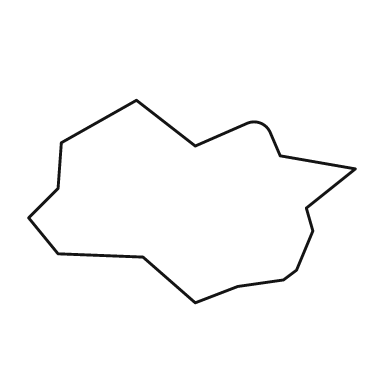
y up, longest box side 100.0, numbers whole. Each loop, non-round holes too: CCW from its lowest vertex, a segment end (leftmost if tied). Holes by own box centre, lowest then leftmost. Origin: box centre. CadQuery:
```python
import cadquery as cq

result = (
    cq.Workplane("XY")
    .moveTo(1.0, -31.0)
    .lineTo(14.0, -26.0)
    .lineTo(28.0, -24.0)
    .lineTo(32.0, -21.0)
    .lineTo(37.0, -9.0)
    .lineTo(35.0, -2.0)
    .lineTo(50.0, 10.0)
    .lineTo(27.0, 14.0)
    .lineTo(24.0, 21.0)
    .threePointArc((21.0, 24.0), (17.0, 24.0))
    .lineTo(1.0, 17.0)
    .lineTo(-17.0, 31.0)
    .lineTo(-40.0, 18.0)
    .lineTo(-41.0, 4.0)
    .lineTo(-50.0, -5.0)
    .lineTo(-41.0, -16.0)
    .lineTo(-15.0, -17.0)
    .close()
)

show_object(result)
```